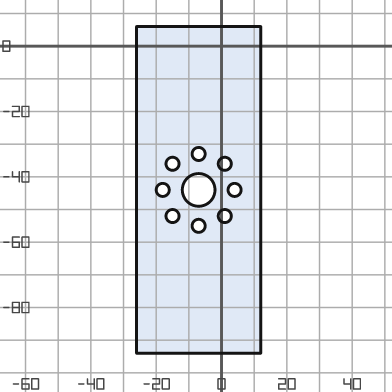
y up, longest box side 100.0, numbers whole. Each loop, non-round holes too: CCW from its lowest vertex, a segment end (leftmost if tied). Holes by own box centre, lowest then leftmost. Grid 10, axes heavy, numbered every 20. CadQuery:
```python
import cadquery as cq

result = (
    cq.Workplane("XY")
    .moveTo(-26.0, -94.0)
    .lineTo(12.0, -94.0)
    .lineTo(12.0, 6.0)
    .lineTo(-26.0, 6.0)
    .close()
    .moveTo(-7.0, -55.0)
    .circle(2.0)
    .moveTo(-15.0, -52.0)
    .circle(2.0)
    .moveTo(1.0, -52.0)
    .circle(2.0)
    .moveTo(-18.0, -44.0)
    .circle(2.0)
    .moveTo(-7.0, -44.0)
    .circle(5.0)
    .moveTo(4.0, -44.0)
    .circle(2.0)
    .moveTo(-15.0, -36.0)
    .circle(2.0)
    .moveTo(1.0, -36.0)
    .circle(2.0)
    .moveTo(-7.0, -33.0)
    .circle(2.0)
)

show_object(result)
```